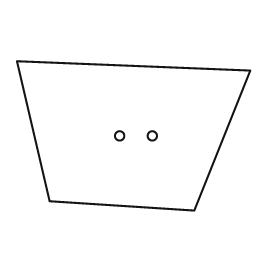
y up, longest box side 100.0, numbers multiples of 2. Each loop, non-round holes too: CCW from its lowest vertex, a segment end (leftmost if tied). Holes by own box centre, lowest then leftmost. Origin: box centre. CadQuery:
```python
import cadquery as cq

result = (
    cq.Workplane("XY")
    .moveTo(26.0, -32.0)
    .lineTo(50.0, 28.0)
    .lineTo(-50.0, 32.0)
    .lineTo(-36.0, -28.0)
    .close()
    .moveTo(-6.0, 0.0)
    .circle(2.0)
    .moveTo(8.0, 0.0)
    .circle(2.0)
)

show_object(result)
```